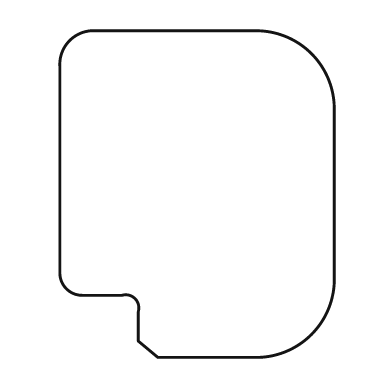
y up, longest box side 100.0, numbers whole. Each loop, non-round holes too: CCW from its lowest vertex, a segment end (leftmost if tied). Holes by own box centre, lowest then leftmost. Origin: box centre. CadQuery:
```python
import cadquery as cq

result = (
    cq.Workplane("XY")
    .moveTo(-12.0, -50.0)
    .lineTo(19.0, -50.0)
    .threePointArc((35.0, -43.0), (42.0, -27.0))
    .lineTo(42.0, 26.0)
    .threePointArc((35.0, 43.0), (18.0, 50.0))
    .lineTo(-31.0, 50.0)
    .threePointArc((-39.0, 47.0), (-42.0, 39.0))
    .lineTo(-42.0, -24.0)
    .threePointArc((-40.0, -29.0), (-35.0, -31.0))
    .lineTo(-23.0, -31.0)
    .threePointArc((-19.0, -32.0), (-18.0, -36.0))
    .lineTo(-18.0, -45.0)
    .close()
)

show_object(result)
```